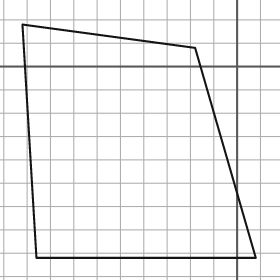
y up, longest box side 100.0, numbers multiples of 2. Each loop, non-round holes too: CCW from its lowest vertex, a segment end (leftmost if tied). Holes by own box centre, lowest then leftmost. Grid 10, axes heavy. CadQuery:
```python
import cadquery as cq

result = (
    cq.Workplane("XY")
    .moveTo(-86.0, -82.0)
    .lineTo(8.0, -82.0)
    .lineTo(-18.0, 8.0)
    .lineTo(-92.0, 18.0)
    .close()
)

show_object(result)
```